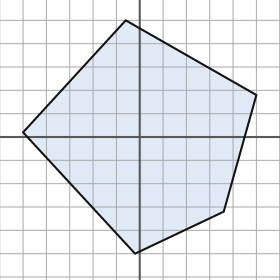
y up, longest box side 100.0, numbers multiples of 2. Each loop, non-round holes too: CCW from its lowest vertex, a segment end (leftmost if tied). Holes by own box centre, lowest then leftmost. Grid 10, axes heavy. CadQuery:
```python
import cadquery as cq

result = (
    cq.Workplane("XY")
    .moveTo(-2.0, -50.0)
    .lineTo(36.0, -32.0)
    .lineTo(50.0, 18.0)
    .lineTo(-6.0, 50.0)
    .lineTo(-50.0, 2.0)
    .close()
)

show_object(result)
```